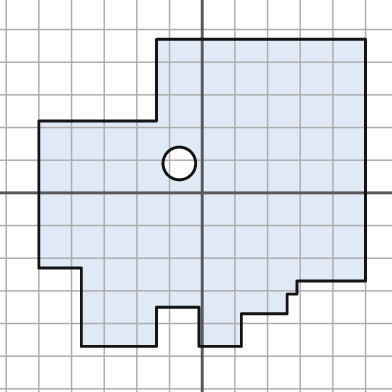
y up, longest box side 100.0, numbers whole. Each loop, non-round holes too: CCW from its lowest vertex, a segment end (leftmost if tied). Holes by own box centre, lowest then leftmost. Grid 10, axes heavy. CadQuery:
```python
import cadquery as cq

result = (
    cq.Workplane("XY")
    .moveTo(-37.0, -47.0)
    .lineTo(-14.0, -47.0)
    .lineTo(-14.0, -35.0)
    .lineTo(-1.0, -35.0)
    .lineTo(-1.0, -47.0)
    .lineTo(12.0, -47.0)
    .lineTo(12.0, -37.0)
    .lineTo(26.0, -37.0)
    .lineTo(26.0, -31.0)
    .lineTo(29.0, -31.0)
    .lineTo(29.0, -27.0)
    .lineTo(50.0, -27.0)
    .lineTo(50.0, 47.0)
    .lineTo(-14.0, 47.0)
    .lineTo(-14.0, 22.0)
    .lineTo(-50.0, 22.0)
    .lineTo(-50.0, -23.0)
    .lineTo(-37.0, -23.0)
    .close()
    .moveTo(-7.0, 9.0)
    .circle(5.0)
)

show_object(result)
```